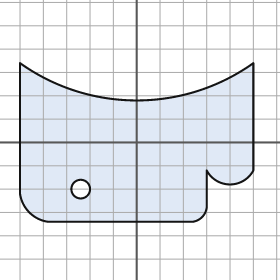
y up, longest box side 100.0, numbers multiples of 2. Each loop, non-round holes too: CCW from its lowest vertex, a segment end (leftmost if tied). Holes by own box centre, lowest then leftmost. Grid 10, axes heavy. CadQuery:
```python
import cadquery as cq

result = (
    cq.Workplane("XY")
    .moveTo(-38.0, -34.0)
    .lineTo(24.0, -34.0)
    .threePointArc((28.0, -32.0), (30.0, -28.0))
    .lineTo(30.0, -12.0)
    .threePointArc((40.0, -18.0), (50.0, -12.0))
    .lineTo(50.0, 34.0)
    .threePointArc((0.0, 18.0), (-50.0, 34.0))
    .lineTo(-50.0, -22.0)
    .threePointArc((-46.0, -30.0), (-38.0, -34.0))
    .close()
    .moveTo(-24.0, -20.0)
    .circle(4.0)
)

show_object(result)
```